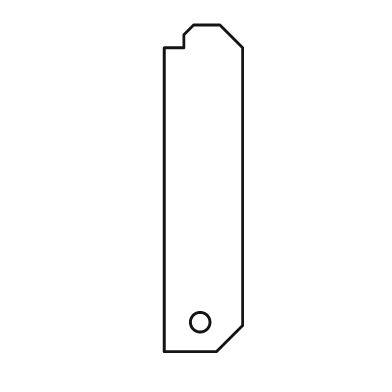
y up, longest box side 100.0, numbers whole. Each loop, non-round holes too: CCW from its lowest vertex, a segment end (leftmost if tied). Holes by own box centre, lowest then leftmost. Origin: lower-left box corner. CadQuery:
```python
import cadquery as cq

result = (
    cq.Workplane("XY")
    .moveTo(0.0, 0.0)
    .lineTo(16.0, 0.0)
    .lineTo(24.0, 8.0)
    .lineTo(24.0, 93.0)
    .lineTo(17.0, 100.0)
    .lineTo(9.0, 100.0)
    .lineTo(6.0, 97.0)
    .lineTo(6.0, 93.0)
    .lineTo(0.0, 93.0)
    .close()
    .moveTo(11.0, 9.0)
    .circle(3.0)
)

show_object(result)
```